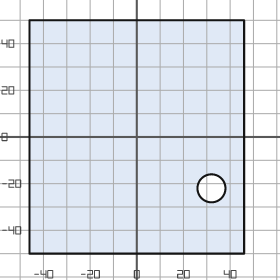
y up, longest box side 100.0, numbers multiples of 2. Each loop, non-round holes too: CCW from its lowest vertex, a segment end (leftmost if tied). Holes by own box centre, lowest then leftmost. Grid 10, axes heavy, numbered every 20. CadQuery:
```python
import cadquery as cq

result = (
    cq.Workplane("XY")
    .moveTo(-46.0, -50.0)
    .lineTo(46.0, -50.0)
    .lineTo(46.0, 50.0)
    .lineTo(-46.0, 50.0)
    .close()
    .moveTo(32.0, -22.0)
    .circle(6.0)
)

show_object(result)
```